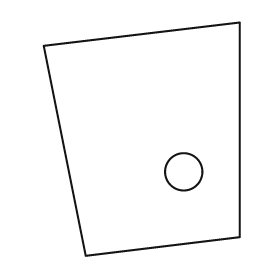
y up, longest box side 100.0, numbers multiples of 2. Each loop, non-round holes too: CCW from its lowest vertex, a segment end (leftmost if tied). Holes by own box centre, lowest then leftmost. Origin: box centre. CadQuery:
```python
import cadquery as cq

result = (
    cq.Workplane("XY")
    .moveTo(-24.0, -50.0)
    .lineTo(42.0, -42.0)
    .lineTo(42.0, 50.0)
    .lineTo(-42.0, 40.0)
    .close()
    .moveTo(18.0, -14.0)
    .circle(8.0)
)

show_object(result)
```